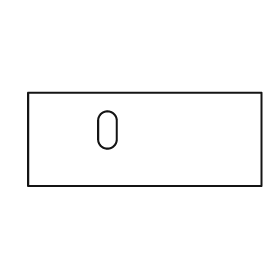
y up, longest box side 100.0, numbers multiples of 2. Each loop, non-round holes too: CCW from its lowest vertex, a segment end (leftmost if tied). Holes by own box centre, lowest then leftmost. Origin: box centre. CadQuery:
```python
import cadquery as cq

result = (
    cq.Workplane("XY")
    .moveTo(-50.0, -20.0)
    .lineTo(50.0, -20.0)
    .lineTo(50.0, 20.0)
    .lineTo(-50.0, 20.0)
    .close()
    .moveTo(-20.0, 0.0)
    .threePointArc((-16.0, -4.0), (-12.0, 0.0))
    .lineTo(-12.0, 8.0)
    .threePointArc((-16.0, 12.0), (-20.0, 8.0))
    .close()
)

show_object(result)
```